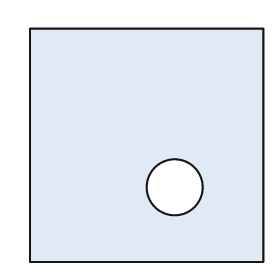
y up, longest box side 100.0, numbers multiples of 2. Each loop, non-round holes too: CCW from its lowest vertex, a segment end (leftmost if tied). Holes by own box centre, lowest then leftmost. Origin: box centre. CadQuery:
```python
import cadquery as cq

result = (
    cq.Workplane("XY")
    .moveTo(-50.0, -50.0)
    .lineTo(50.0, -50.0)
    .lineTo(50.0, 50.0)
    .lineTo(-50.0, 50.0)
    .close()
    .moveTo(12.0, -18.0)
    .circle(12.0)
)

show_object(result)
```